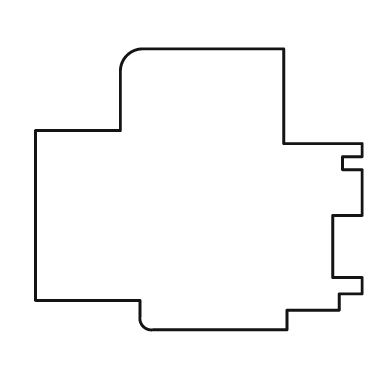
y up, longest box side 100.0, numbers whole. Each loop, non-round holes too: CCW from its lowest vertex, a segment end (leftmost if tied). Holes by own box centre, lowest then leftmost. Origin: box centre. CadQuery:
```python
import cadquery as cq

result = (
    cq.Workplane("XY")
    .moveTo(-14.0, -43.0)
    .lineTo(27.0, -43.0)
    .lineTo(27.0, -37.0)
    .lineTo(43.0, -37.0)
    .lineTo(43.0, -32.0)
    .lineTo(50.0, -32.0)
    .lineTo(50.0, -27.0)
    .lineTo(41.0, -27.0)
    .lineTo(41.0, -8.0)
    .lineTo(50.0, -8.0)
    .lineTo(50.0, 6.0)
    .lineTo(44.0, 6.0)
    .lineTo(44.0, 10.0)
    .lineTo(50.0, 10.0)
    .lineTo(50.0, 14.0)
    .lineTo(26.0, 14.0)
    .lineTo(26.0, 43.0)
    .lineTo(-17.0, 43.0)
    .threePointArc((-22.0, 41.0), (-24.0, 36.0))
    .lineTo(-24.0, 18.0)
    .lineTo(-50.0, 18.0)
    .lineTo(-50.0, -34.0)
    .lineTo(-18.0, -34.0)
    .lineTo(-18.0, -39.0)
    .threePointArc((-17.0, -42.0), (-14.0, -43.0))
    .close()
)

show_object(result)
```